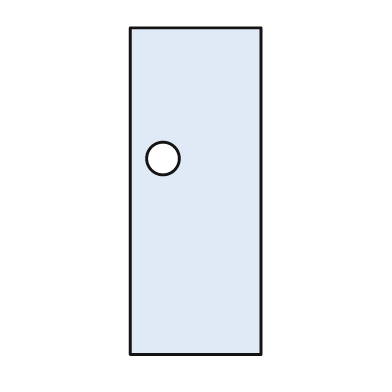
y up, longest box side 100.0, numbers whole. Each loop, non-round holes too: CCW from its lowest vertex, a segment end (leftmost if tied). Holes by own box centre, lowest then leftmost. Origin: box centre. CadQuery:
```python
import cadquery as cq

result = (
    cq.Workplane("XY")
    .moveTo(-20.0, -50.0)
    .lineTo(20.0, -50.0)
    .lineTo(20.0, 50.0)
    .lineTo(-20.0, 50.0)
    .close()
    .moveTo(-10.0, 10.0)
    .circle(5.0)
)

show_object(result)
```